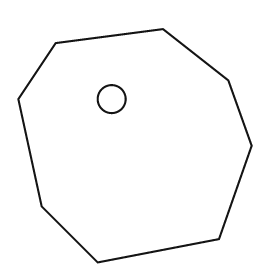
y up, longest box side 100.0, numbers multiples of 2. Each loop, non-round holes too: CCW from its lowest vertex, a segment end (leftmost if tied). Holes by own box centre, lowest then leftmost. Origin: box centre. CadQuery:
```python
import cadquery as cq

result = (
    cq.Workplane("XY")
    .moveTo(-16.0, -50.0)
    .lineTo(36.0, -40.0)
    .lineTo(50.0, 0.0)
    .lineTo(40.0, 28.0)
    .lineTo(12.0, 50.0)
    .lineTo(-34.0, 44.0)
    .lineTo(-50.0, 20.0)
    .lineTo(-40.0, -26.0)
    .close()
    .moveTo(-10.0, 20.0)
    .circle(6.0)
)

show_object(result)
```